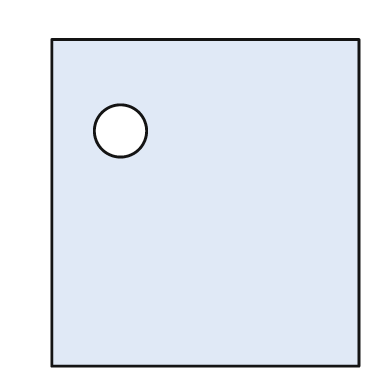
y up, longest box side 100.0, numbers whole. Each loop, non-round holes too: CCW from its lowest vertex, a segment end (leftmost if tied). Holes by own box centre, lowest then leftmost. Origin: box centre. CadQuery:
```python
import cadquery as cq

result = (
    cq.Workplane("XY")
    .moveTo(-47.0, -50.0)
    .lineTo(47.0, -50.0)
    .lineTo(47.0, 50.0)
    .lineTo(-47.0, 50.0)
    .close()
    .moveTo(-26.0, 22.0)
    .circle(8.0)
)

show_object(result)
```